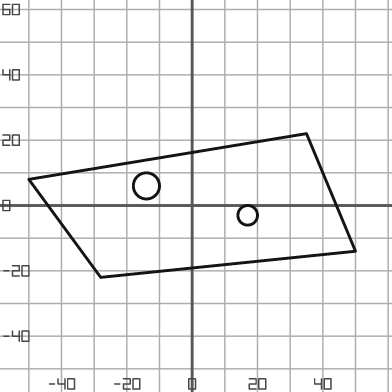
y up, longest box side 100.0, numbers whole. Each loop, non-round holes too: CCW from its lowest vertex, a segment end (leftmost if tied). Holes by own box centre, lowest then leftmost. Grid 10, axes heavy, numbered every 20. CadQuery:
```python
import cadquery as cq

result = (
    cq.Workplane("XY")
    .moveTo(-28.0, -22.0)
    .lineTo(50.0, -14.0)
    .lineTo(35.0, 22.0)
    .lineTo(-50.0, 8.0)
    .close()
    .moveTo(17.0, -3.0)
    .circle(3.0)
    .moveTo(-14.0, 6.0)
    .circle(4.0)
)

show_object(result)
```